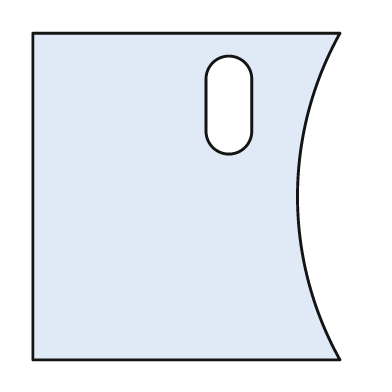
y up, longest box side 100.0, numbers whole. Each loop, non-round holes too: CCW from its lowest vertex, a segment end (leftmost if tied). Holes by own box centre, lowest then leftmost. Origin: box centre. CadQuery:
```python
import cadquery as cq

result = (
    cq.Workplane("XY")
    .moveTo(-47.0, -50.0)
    .lineTo(47.0, -50.0)
    .threePointArc((34.0, 0.0), (47.0, 50.0))
    .lineTo(-47.0, 50.0)
    .close()
    .moveTo(6.0, 20.0)
    .threePointArc((13.0, 13.0), (20.0, 20.0))
    .lineTo(20.0, 36.0)
    .threePointArc((13.0, 43.0), (6.0, 36.0))
    .close()
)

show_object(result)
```